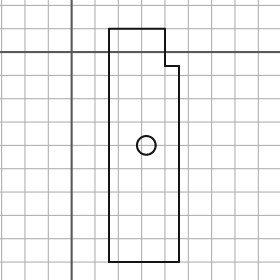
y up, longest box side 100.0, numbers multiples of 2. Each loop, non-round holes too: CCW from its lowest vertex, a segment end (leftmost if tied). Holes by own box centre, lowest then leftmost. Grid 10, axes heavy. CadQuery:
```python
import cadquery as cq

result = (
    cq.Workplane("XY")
    .moveTo(16.0, -90.0)
    .lineTo(46.0, -90.0)
    .lineTo(46.0, -6.0)
    .lineTo(40.0, -6.0)
    .lineTo(40.0, 10.0)
    .lineTo(16.0, 10.0)
    .close()
    .moveTo(32.0, -40.0)
    .circle(4.0)
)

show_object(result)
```